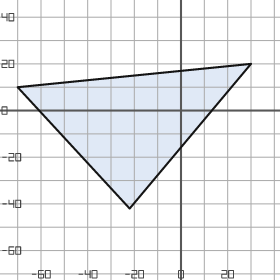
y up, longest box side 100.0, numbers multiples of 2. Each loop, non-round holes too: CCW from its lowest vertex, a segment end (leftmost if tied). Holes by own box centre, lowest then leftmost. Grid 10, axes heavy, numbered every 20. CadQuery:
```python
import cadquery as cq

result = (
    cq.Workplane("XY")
    .moveTo(-22.0, -42.0)
    .lineTo(30.0, 20.0)
    .lineTo(-70.0, 10.0)
    .close()
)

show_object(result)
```